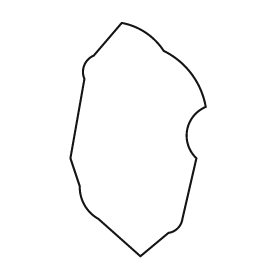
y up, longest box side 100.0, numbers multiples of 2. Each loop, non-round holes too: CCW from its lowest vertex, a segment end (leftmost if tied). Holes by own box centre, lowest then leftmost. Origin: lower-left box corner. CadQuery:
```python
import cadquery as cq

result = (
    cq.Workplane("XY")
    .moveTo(30.0, 0.0)
    .lineTo(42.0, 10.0)
    .threePointArc((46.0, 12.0), (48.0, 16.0))
    .lineTo(54.0, 42.0)
    .threePointArc((50.0, 54.0), (58.0, 64.0))
    .threePointArc((52.0, 78.0), (40.0, 88.0))
    .threePointArc((32.0, 96.0), (22.0, 100.0))
    .lineTo(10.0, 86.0)
    .threePointArc((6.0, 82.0), (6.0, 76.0))
    .lineTo(0.0, 42.0)
    .lineTo(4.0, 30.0)
    .threePointArc((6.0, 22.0), (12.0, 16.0))
    .close()
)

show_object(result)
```